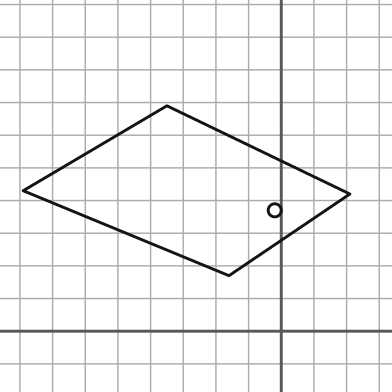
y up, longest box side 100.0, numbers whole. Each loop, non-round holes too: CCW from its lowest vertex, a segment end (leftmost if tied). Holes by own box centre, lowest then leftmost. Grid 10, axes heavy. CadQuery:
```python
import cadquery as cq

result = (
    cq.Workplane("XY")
    .moveTo(-16.0, 17.0)
    .lineTo(21.0, 42.0)
    .lineTo(-35.0, 69.0)
    .lineTo(-79.0, 43.0)
    .close()
    .moveTo(-2.0, 37.0)
    .circle(2.0)
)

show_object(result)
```